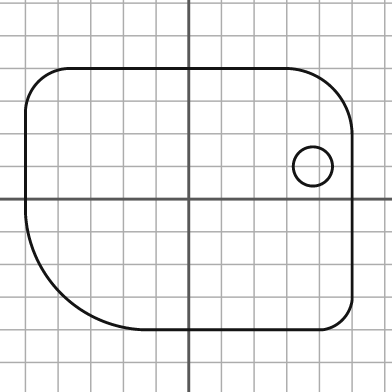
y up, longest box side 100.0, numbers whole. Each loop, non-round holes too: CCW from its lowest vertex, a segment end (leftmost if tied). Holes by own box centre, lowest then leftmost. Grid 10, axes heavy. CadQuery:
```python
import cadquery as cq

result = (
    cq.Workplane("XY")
    .moveTo(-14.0, -40.0)
    .lineTo(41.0, -40.0)
    .threePointArc((47.0, -37.0), (50.0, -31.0))
    .lineTo(50.0, 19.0)
    .threePointArc((44.0, 34.0), (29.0, 40.0))
    .lineTo(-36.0, 40.0)
    .threePointArc((-46.0, 36.0), (-50.0, 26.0))
    .lineTo(-50.0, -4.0)
    .threePointArc((-39.0, -29.0), (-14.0, -40.0))
    .close()
    .moveTo(38.0, 10.0)
    .circle(6.0)
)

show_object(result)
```